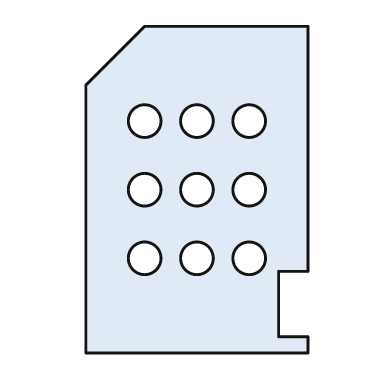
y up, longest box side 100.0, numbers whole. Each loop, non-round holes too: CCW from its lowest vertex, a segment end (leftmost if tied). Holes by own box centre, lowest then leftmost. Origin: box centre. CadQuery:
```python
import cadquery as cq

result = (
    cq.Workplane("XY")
    .moveTo(-34.0, -50.0)
    .lineTo(34.0, -50.0)
    .lineTo(34.0, -45.0)
    .lineTo(25.0, -45.0)
    .lineTo(25.0, -25.0)
    .lineTo(34.0, -25.0)
    .lineTo(34.0, 50.0)
    .lineTo(-16.0, 50.0)
    .lineTo(-34.0, 32.0)
    .close()
    .moveTo(-16.0, -21.0)
    .circle(5.0)
    .moveTo(0.0, -21.0)
    .circle(5.0)
    .moveTo(16.0, -21.0)
    .circle(5.0)
    .moveTo(-16.0, 0.0)
    .circle(5.0)
    .moveTo(0.0, 0.0)
    .circle(5.0)
    .moveTo(16.0, 0.0)
    .circle(5.0)
    .moveTo(-16.0, 21.0)
    .circle(5.0)
    .moveTo(0.0, 21.0)
    .circle(5.0)
    .moveTo(16.0, 21.0)
    .circle(5.0)
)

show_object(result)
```